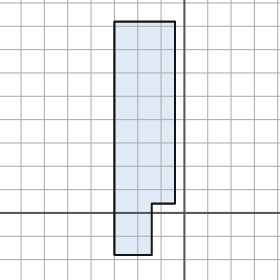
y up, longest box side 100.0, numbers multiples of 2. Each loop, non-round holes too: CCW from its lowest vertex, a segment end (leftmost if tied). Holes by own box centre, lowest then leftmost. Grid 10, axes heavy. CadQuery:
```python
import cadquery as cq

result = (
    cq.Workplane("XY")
    .moveTo(-30.0, -18.0)
    .lineTo(-14.0, -18.0)
    .lineTo(-14.0, 4.0)
    .lineTo(-4.0, 4.0)
    .lineTo(-4.0, 82.0)
    .lineTo(-30.0, 82.0)
    .close()
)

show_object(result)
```